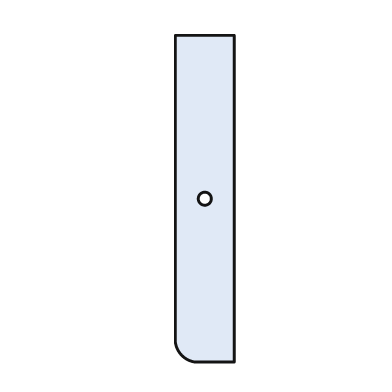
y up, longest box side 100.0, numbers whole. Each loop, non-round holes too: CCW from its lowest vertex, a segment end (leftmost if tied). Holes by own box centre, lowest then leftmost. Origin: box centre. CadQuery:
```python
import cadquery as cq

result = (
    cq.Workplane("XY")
    .moveTo(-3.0, -50.0)
    .lineTo(9.0, -50.0)
    .lineTo(9.0, 50.0)
    .lineTo(-9.0, 50.0)
    .lineTo(-9.0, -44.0)
    .threePointArc((-7.0, -48.0), (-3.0, -50.0))
    .close()
    .moveTo(0.0, 0.0)
    .circle(2.0)
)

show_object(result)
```